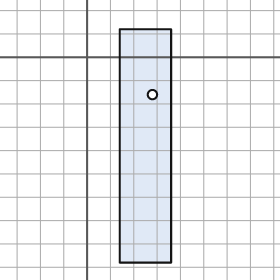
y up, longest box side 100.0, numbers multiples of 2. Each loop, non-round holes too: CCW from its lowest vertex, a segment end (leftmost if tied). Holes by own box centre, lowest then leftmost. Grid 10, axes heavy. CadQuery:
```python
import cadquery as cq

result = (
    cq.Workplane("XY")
    .moveTo(14.0, -88.0)
    .lineTo(36.0, -88.0)
    .lineTo(36.0, 12.0)
    .lineTo(14.0, 12.0)
    .close()
    .moveTo(28.0, -16.0)
    .circle(2.0)
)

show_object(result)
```